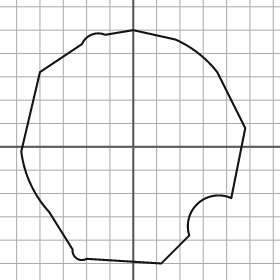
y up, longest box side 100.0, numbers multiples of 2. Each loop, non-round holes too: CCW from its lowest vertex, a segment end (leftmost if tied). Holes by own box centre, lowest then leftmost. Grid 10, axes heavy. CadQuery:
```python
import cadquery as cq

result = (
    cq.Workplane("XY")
    .moveTo(12.0, -50.0)
    .lineTo(24.0, -38.0)
    .threePointArc((28.0, -24.0), (42.0, -22.0))
    .lineTo(48.0, 8.0)
    .lineTo(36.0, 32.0)
    .threePointArc((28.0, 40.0), (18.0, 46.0))
    .lineTo(0.0, 50.0)
    .lineTo(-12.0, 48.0)
    .threePointArc((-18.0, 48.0), (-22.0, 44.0))
    .lineTo(-40.0, 32.0)
    .lineTo(-48.0, -2.0)
    .threePointArc((-44.0, -16.0), (-36.0, -28.0))
    .lineTo(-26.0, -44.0)
    .threePointArc((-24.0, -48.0), (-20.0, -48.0))
    .close()
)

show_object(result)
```